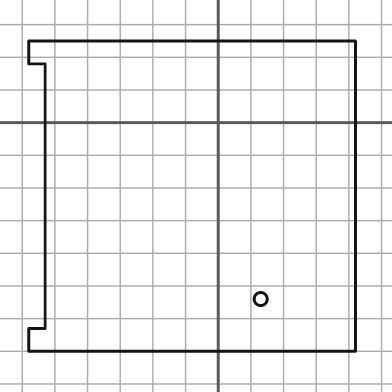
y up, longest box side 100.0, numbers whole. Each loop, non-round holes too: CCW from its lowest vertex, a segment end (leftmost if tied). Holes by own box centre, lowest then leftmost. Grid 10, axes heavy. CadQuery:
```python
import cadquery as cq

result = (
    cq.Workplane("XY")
    .moveTo(-58.0, -70.0)
    .lineTo(42.0, -70.0)
    .lineTo(42.0, 25.0)
    .lineTo(-58.0, 25.0)
    .lineTo(-58.0, 18.0)
    .lineTo(-53.0, 18.0)
    .lineTo(-53.0, -63.0)
    .lineTo(-58.0, -63.0)
    .close()
    .moveTo(13.0, -54.0)
    .circle(2.0)
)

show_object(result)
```